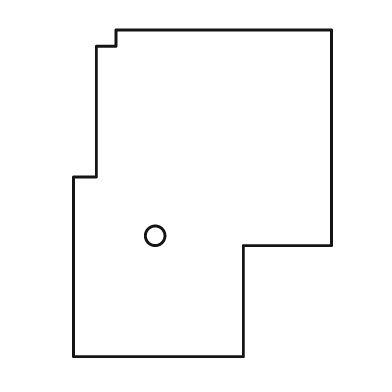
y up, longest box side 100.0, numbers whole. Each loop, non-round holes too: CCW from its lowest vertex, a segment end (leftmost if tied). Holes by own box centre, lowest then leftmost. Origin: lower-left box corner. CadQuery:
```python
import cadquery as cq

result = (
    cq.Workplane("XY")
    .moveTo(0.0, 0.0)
    .lineTo(52.0, 0.0)
    .lineTo(52.0, 34.0)
    .lineTo(79.0, 34.0)
    .lineTo(79.0, 100.0)
    .lineTo(13.0, 100.0)
    .lineTo(13.0, 95.0)
    .lineTo(7.0, 95.0)
    .lineTo(7.0, 55.0)
    .lineTo(0.0, 55.0)
    .close()
    .moveTo(25.0, 37.0)
    .circle(3.0)
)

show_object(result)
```